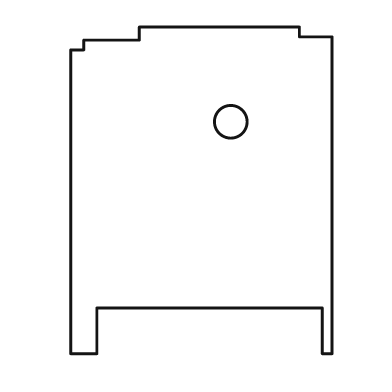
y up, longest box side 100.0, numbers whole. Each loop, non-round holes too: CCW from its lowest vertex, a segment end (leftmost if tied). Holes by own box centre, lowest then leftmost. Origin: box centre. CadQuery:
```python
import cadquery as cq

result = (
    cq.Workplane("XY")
    .moveTo(-40.0, -50.0)
    .lineTo(-32.0, -50.0)
    .lineTo(-32.0, -36.0)
    .lineTo(37.0, -36.0)
    .lineTo(37.0, -50.0)
    .lineTo(40.0, -50.0)
    .lineTo(40.0, 47.0)
    .lineTo(30.0, 47.0)
    .lineTo(30.0, 50.0)
    .lineTo(-19.0, 50.0)
    .lineTo(-19.0, 46.0)
    .lineTo(-36.0, 46.0)
    .lineTo(-36.0, 43.0)
    .lineTo(-40.0, 43.0)
    .close()
    .moveTo(9.0, 21.0)
    .circle(5.0)
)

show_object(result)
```